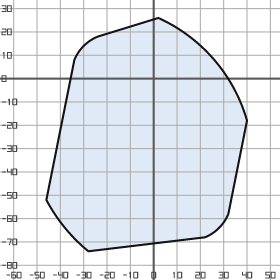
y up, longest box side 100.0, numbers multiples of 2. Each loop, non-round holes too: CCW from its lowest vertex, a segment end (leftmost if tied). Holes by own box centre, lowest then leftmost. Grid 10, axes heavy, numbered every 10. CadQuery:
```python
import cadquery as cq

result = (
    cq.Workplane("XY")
    .moveTo(-28.0, -74.0)
    .lineTo(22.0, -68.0)
    .threePointArc((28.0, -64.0), (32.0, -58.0))
    .lineTo(40.0, -18.0)
    .threePointArc((26.0, 8.0), (2.0, 26.0))
    .lineTo(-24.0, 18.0)
    .threePointArc((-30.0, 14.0), (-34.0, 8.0))
    .lineTo(-46.0, -52.0)
    .threePointArc((-38.0, -64.0), (-28.0, -74.0))
    .close()
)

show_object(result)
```